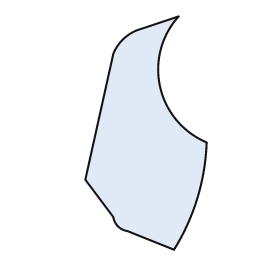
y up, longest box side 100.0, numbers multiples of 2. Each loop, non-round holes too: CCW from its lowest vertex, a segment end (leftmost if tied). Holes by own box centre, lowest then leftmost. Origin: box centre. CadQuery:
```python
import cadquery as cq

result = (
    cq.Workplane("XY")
    .moveTo(12.0, -50.0)
    .threePointArc((22.0, -28.0), (26.0, -4.0))
    .threePointArc((6.0, 20.0), (14.0, 50.0))
    .lineTo(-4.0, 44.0)
    .threePointArc((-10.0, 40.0), (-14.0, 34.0))
    .lineTo(-26.0, -20.0)
    .lineTo(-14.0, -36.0)
    .threePointArc((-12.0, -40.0), (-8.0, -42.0))
    .close()
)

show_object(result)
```